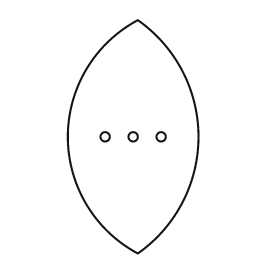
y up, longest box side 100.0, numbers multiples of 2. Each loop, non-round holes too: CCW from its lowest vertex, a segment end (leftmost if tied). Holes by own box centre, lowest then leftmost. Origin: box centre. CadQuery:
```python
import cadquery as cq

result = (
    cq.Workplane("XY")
    .moveTo(2.0, -50.0)
    .threePointArc((28.0, 0.0), (2.0, 50.0))
    .threePointArc((-28.0, 0.0), (2.0, -50.0))
    .close()
    .moveTo(-12.0, 0.0)
    .circle(2.0)
    .moveTo(0.0, 0.0)
    .circle(2.0)
    .moveTo(12.0, 0.0)
    .circle(2.0)
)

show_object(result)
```